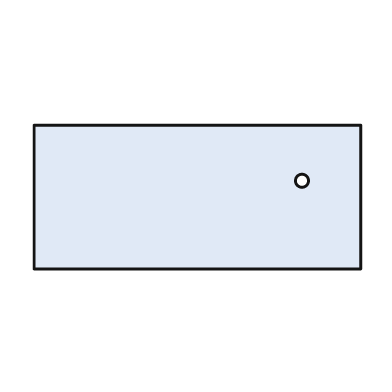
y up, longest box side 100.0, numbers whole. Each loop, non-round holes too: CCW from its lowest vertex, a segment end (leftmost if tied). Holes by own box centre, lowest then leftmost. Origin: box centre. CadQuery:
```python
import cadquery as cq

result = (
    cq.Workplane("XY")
    .moveTo(-50.0, -22.0)
    .lineTo(50.0, -22.0)
    .lineTo(50.0, 22.0)
    .lineTo(-50.0, 22.0)
    .close()
    .moveTo(32.0, 5.0)
    .circle(2.0)
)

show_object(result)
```